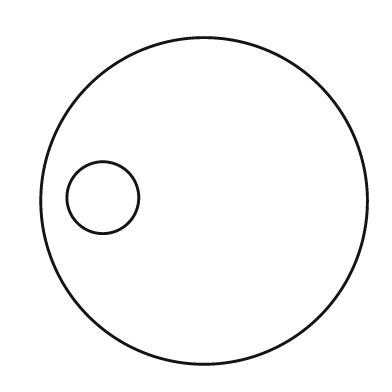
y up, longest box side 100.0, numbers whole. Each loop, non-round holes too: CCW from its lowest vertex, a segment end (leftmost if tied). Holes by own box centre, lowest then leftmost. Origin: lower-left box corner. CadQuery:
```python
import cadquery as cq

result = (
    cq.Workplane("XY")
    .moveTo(50.0, 50.0)
    .circle(50.0)
    .moveTo(19.0, 51.0)
    .circle(11.0)
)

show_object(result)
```